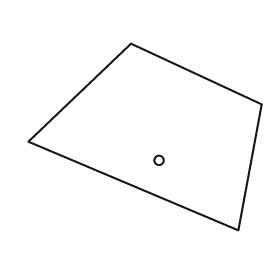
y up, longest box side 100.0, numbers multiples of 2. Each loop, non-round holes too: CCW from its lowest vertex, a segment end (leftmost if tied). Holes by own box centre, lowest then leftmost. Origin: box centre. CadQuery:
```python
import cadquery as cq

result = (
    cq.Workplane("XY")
    .moveTo(40.0, -40.0)
    .lineTo(50.0, 14.0)
    .lineTo(-6.0, 40.0)
    .lineTo(-50.0, -2.0)
    .close()
    .moveTo(6.0, -10.0)
    .circle(2.0)
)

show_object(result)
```